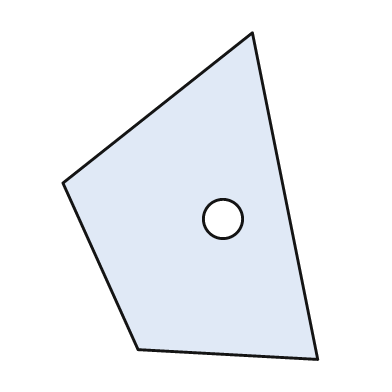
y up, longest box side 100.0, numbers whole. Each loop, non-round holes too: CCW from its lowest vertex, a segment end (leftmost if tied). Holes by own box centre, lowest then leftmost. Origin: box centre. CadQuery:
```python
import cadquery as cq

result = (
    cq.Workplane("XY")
    .moveTo(39.0, -50.0)
    .lineTo(19.0, 50.0)
    .lineTo(-39.0, 4.0)
    .lineTo(-16.0, -47.0)
    .close()
    .moveTo(10.0, -7.0)
    .circle(6.0)
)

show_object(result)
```